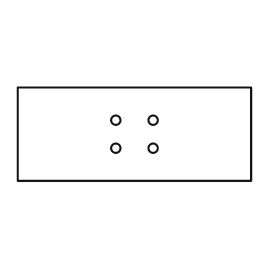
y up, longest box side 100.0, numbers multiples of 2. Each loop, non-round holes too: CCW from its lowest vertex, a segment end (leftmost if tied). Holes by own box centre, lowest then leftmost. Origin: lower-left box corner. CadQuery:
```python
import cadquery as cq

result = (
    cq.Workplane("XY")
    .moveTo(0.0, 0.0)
    .lineTo(100.0, 0.0)
    .lineTo(100.0, 40.0)
    .lineTo(0.0, 40.0)
    .close()
    .moveTo(42.0, 14.0)
    .circle(2.0)
    .moveTo(58.0, 14.0)
    .circle(2.0)
    .moveTo(42.0, 26.0)
    .circle(2.0)
    .moveTo(58.0, 26.0)
    .circle(2.0)
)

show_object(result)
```